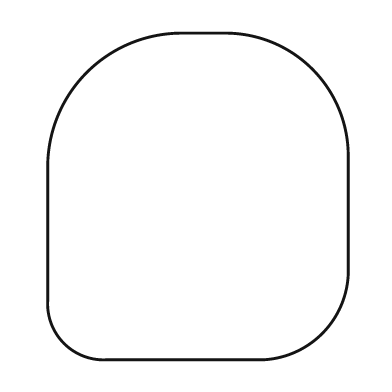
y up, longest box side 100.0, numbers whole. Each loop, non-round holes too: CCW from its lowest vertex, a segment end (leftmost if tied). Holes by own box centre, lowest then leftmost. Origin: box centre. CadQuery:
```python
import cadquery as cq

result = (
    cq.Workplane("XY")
    .moveTo(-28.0, -50.0)
    .lineTo(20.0, -50.0)
    .threePointArc((38.0, -42.0), (46.0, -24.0))
    .lineTo(46.0, 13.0)
    .threePointArc((35.0, 39.0), (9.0, 50.0))
    .lineTo(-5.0, 50.0)
    .threePointArc((-34.0, 38.0), (-46.0, 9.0))
    .lineTo(-46.0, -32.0)
    .threePointArc((-41.0, -45.0), (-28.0, -50.0))
    .close()
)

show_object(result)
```